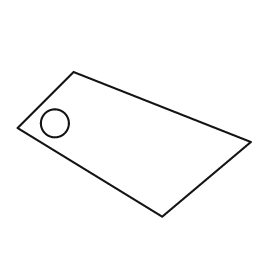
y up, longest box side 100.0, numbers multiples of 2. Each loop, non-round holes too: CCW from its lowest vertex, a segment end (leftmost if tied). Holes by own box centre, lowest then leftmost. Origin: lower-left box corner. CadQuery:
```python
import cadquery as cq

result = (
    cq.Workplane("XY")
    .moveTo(62.0, 0.0)
    .lineTo(100.0, 32.0)
    .lineTo(24.0, 62.0)
    .lineTo(0.0, 38.0)
    .close()
    .moveTo(16.0, 40.0)
    .circle(6.0)
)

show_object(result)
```